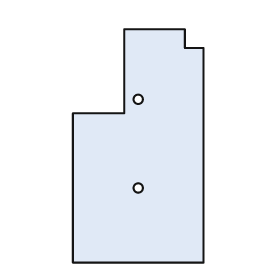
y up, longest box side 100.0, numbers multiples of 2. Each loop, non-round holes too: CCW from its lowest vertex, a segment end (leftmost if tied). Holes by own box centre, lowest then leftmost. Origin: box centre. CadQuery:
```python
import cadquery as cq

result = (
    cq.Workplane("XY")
    .moveTo(-28.0, -50.0)
    .lineTo(28.0, -50.0)
    .lineTo(28.0, 42.0)
    .lineTo(20.0, 42.0)
    .lineTo(20.0, 50.0)
    .lineTo(-6.0, 50.0)
    .lineTo(-6.0, 14.0)
    .lineTo(-28.0, 14.0)
    .close()
    .moveTo(0.0, -18.0)
    .circle(2.0)
    .moveTo(0.0, 20.0)
    .circle(2.0)
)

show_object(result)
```